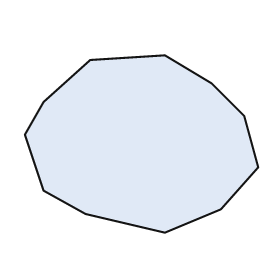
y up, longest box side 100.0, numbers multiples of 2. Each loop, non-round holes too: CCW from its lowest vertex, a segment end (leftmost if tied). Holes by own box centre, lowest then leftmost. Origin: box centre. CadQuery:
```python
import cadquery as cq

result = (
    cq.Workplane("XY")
    .moveTo(10.0, -38.0)
    .lineTo(34.0, -28.0)
    .lineTo(50.0, -10.0)
    .lineTo(44.0, 12.0)
    .lineTo(30.0, 26.0)
    .lineTo(10.0, 38.0)
    .lineTo(-22.0, 36.0)
    .lineTo(-42.0, 18.0)
    .lineTo(-50.0, 4.0)
    .lineTo(-42.0, -20.0)
    .lineTo(-24.0, -30.0)
    .close()
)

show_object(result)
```